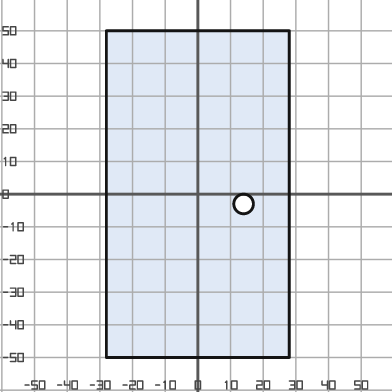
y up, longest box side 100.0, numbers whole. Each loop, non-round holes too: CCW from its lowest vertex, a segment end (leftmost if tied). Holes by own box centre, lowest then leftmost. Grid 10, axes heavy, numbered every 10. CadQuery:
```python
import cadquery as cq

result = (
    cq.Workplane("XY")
    .moveTo(-28.0, -50.0)
    .lineTo(28.0, -50.0)
    .lineTo(28.0, 50.0)
    .lineTo(-28.0, 50.0)
    .close()
    .moveTo(14.0, -3.0)
    .circle(3.0)
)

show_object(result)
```